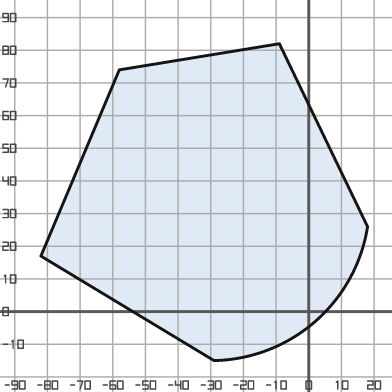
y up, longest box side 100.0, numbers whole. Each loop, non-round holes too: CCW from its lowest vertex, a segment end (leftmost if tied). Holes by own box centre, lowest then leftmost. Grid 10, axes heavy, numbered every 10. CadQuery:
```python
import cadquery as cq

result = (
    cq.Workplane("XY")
    .moveTo(-29.0, -15.0)
    .threePointArc((2.0, -3.0), (18.0, 26.0))
    .lineTo(-9.0, 82.0)
    .lineTo(-58.0, 74.0)
    .lineTo(-82.0, 17.0)
    .close()
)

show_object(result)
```